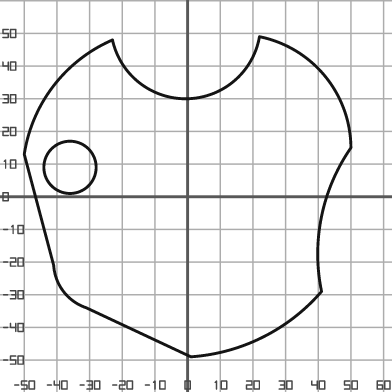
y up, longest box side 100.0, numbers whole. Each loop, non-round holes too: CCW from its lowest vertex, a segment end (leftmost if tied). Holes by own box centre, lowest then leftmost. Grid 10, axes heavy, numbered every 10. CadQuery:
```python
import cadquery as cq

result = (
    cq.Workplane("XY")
    .moveTo(1.0, -49.0)
    .threePointArc((23.0, -43.0), (41.0, -29.0))
    .threePointArc((41.0, -6.0), (50.0, 15.0))
    .threePointArc((42.0, 37.0), (22.0, 49.0))
    .threePointArc((0.0, 30.0), (-23.0, 48.0))
    .threePointArc((-41.0, 34.0), (-50.0, 13.0))
    .lineTo(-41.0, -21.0)
    .threePointArc((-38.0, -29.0), (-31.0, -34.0))
    .close()
    .moveTo(-36.0, 9.0)
    .circle(8.0)
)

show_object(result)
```